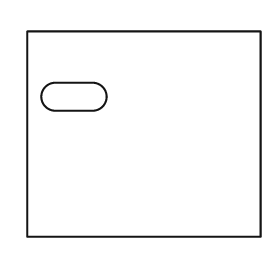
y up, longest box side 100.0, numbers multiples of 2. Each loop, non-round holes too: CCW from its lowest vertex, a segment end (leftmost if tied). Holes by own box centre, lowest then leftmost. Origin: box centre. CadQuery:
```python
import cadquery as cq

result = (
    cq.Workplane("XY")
    .moveTo(-50.0, -44.0)
    .lineTo(50.0, -44.0)
    .lineTo(50.0, 44.0)
    .lineTo(-50.0, 44.0)
    .close()
    .moveTo(-38.0, 10.0)
    .lineTo(-22.0, 10.0)
    .threePointArc((-16.0, 16.0), (-22.0, 22.0))
    .lineTo(-38.0, 22.0)
    .threePointArc((-44.0, 16.0), (-38.0, 10.0))
    .close()
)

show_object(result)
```